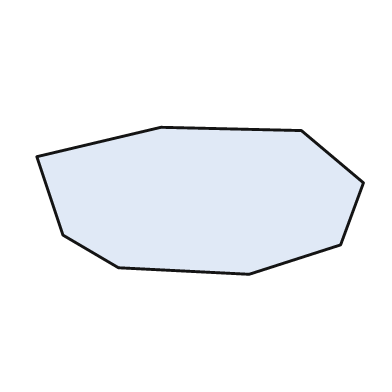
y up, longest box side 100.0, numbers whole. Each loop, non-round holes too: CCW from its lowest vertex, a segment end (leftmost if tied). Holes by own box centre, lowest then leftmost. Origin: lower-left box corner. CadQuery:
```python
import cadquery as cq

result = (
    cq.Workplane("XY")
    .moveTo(65.0, 0.0)
    .lineTo(93.0, 9.0)
    .lineTo(100.0, 28.0)
    .lineTo(81.0, 44.0)
    .lineTo(38.0, 45.0)
    .lineTo(0.0, 36.0)
    .lineTo(8.0, 12.0)
    .lineTo(25.0, 2.0)
    .close()
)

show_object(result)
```